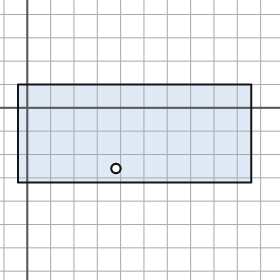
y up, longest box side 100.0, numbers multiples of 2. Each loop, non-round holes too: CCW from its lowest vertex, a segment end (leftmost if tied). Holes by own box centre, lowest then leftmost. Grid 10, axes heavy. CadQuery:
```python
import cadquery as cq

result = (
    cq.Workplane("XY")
    .moveTo(-4.0, -32.0)
    .lineTo(96.0, -32.0)
    .lineTo(96.0, 10.0)
    .lineTo(-4.0, 10.0)
    .close()
    .moveTo(38.0, -26.0)
    .circle(2.0)
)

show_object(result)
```